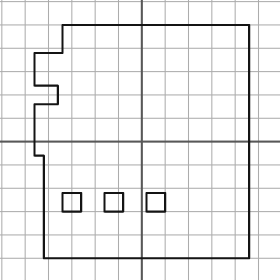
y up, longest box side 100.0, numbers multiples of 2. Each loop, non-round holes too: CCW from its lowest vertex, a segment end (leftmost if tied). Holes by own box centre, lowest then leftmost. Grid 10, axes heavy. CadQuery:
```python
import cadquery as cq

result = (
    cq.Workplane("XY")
    .moveTo(-42.0, -50.0)
    .lineTo(46.0, -50.0)
    .lineTo(46.0, 50.0)
    .lineTo(-34.0, 50.0)
    .lineTo(-34.0, 38.0)
    .lineTo(-46.0, 38.0)
    .lineTo(-46.0, 24.0)
    .lineTo(-36.0, 24.0)
    .lineTo(-36.0, 16.0)
    .lineTo(-46.0, 16.0)
    .lineTo(-46.0, -6.0)
    .lineTo(-42.0, -6.0)
    .close()
    .moveTo(-34.0, -30.0)
    .lineTo(-26.0, -30.0)
    .lineTo(-26.0, -22.0)
    .lineTo(-34.0, -22.0)
    .close()
    .moveTo(-16.0, -30.0)
    .lineTo(-8.0, -30.0)
    .lineTo(-8.0, -22.0)
    .lineTo(-16.0, -22.0)
    .close()
    .moveTo(2.0, -30.0)
    .lineTo(10.0, -30.0)
    .lineTo(10.0, -22.0)
    .lineTo(2.0, -22.0)
    .close()
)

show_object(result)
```